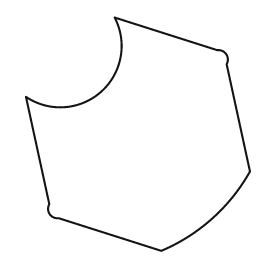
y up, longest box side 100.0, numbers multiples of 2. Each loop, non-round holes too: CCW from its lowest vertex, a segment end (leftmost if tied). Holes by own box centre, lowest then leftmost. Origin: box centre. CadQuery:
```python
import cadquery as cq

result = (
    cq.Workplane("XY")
    .moveTo(10.0, -50.0)
    .threePointArc((32.0, -36.0), (48.0, -16.0))
    .lineTo(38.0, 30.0)
    .threePointArc((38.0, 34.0), (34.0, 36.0))
    .lineTo(-10.0, 50.0)
    .threePointArc((-16.0, 18.0), (-48.0, 16.0))
    .lineTo(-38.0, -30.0)
    .threePointArc((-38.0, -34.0), (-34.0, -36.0))
    .close()
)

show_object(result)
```